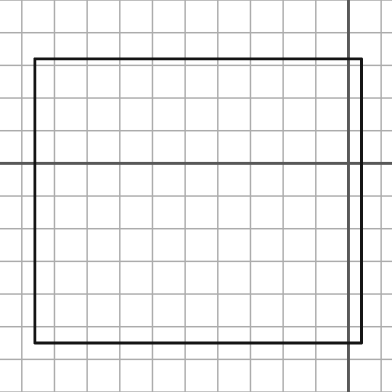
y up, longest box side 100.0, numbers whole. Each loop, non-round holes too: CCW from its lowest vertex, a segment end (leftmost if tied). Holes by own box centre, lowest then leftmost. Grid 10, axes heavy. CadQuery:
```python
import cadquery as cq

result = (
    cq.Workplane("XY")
    .moveTo(-96.0, -55.0)
    .lineTo(4.0, -55.0)
    .lineTo(4.0, 32.0)
    .lineTo(-96.0, 32.0)
    .close()
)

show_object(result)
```